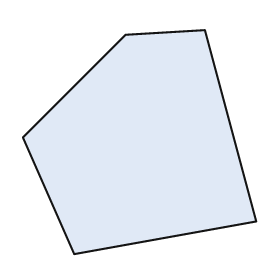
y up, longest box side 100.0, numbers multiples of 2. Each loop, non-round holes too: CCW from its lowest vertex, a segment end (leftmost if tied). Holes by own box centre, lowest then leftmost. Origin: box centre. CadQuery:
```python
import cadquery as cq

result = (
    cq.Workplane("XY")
    .moveTo(-28.0, -48.0)
    .lineTo(50.0, -34.0)
    .lineTo(28.0, 48.0)
    .lineTo(-6.0, 46.0)
    .lineTo(-50.0, 2.0)
    .close()
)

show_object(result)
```